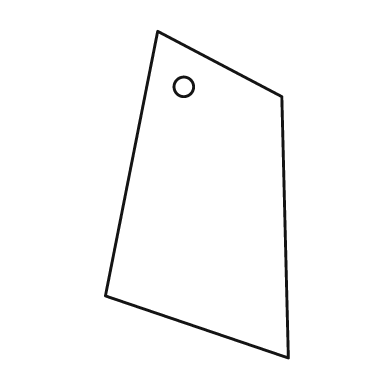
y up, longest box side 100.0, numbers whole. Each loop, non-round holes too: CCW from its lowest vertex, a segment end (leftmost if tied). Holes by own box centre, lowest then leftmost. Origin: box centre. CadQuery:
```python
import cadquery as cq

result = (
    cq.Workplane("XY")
    .moveTo(28.0, -50.0)
    .lineTo(26.0, 30.0)
    .lineTo(-12.0, 50.0)
    .lineTo(-28.0, -31.0)
    .close()
    .moveTo(-4.0, 33.0)
    .circle(3.0)
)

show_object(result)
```